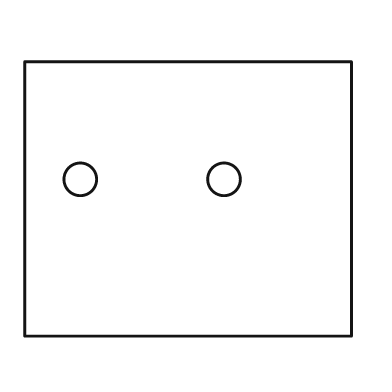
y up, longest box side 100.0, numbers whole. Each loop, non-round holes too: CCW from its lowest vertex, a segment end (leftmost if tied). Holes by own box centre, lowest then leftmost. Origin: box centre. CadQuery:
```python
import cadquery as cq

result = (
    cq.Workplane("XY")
    .moveTo(-50.0, -42.0)
    .lineTo(50.0, -42.0)
    .lineTo(50.0, 42.0)
    .lineTo(-50.0, 42.0)
    .close()
    .moveTo(-33.0, 6.0)
    .circle(5.0)
    .moveTo(11.0, 6.0)
    .circle(5.0)
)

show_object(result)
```